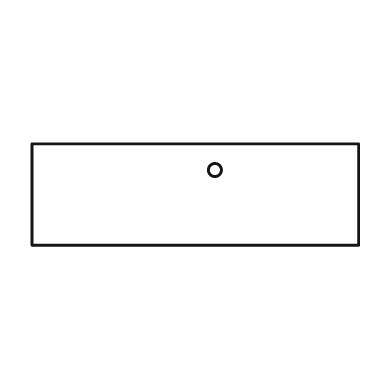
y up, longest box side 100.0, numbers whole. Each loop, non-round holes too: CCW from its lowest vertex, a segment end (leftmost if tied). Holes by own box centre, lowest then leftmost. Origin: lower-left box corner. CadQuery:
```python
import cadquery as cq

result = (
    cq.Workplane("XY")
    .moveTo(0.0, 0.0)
    .lineTo(100.0, 0.0)
    .lineTo(100.0, 31.0)
    .lineTo(0.0, 31.0)
    .close()
    .moveTo(56.0, 23.0)
    .circle(2.0)
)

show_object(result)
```